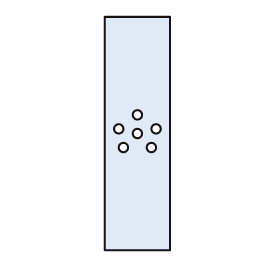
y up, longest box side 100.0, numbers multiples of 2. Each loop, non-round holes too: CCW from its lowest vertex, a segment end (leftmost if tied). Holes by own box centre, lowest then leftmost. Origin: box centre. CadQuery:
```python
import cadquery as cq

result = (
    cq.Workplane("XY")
    .moveTo(-14.0, -50.0)
    .lineTo(14.0, -50.0)
    .lineTo(14.0, 50.0)
    .lineTo(-14.0, 50.0)
    .close()
    .moveTo(-6.0, -6.0)
    .circle(2.0)
    .moveTo(6.0, -6.0)
    .circle(2.0)
    .moveTo(0.0, 0.0)
    .circle(2.0)
    .moveTo(-8.0, 2.0)
    .circle(2.0)
    .moveTo(8.0, 2.0)
    .circle(2.0)
    .moveTo(0.0, 8.0)
    .circle(2.0)
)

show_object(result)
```